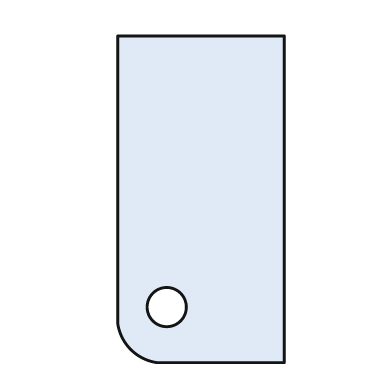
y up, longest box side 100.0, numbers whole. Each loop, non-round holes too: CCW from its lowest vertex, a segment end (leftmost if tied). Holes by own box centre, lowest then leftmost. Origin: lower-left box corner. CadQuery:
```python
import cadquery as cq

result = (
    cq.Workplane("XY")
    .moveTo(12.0, 0.0)
    .lineTo(51.0, 0.0)
    .lineTo(51.0, 100.0)
    .lineTo(0.0, 100.0)
    .lineTo(0.0, 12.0)
    .threePointArc((4.0, 4.0), (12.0, 0.0))
    .close()
    .moveTo(15.0, 17.0)
    .circle(6.0)
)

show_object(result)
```